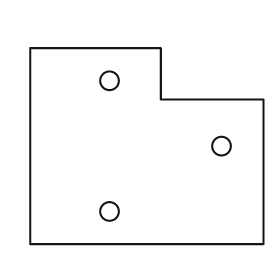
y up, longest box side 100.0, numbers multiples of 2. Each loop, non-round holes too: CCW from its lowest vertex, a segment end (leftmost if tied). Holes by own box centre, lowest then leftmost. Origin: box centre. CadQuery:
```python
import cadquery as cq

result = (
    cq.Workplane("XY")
    .moveTo(-50.0, -42.0)
    .lineTo(50.0, -42.0)
    .lineTo(50.0, 20.0)
    .lineTo(6.0, 20.0)
    .lineTo(6.0, 42.0)
    .lineTo(-50.0, 42.0)
    .close()
    .moveTo(-16.0, -28.0)
    .circle(4.0)
    .moveTo(32.0, 0.0)
    .circle(4.0)
    .moveTo(-16.0, 28.0)
    .circle(4.0)
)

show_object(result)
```